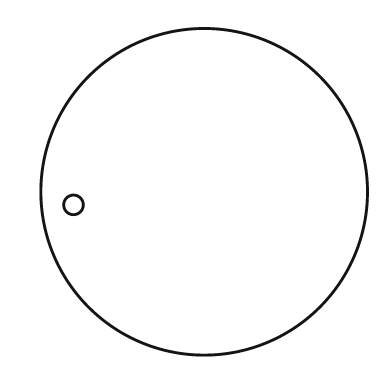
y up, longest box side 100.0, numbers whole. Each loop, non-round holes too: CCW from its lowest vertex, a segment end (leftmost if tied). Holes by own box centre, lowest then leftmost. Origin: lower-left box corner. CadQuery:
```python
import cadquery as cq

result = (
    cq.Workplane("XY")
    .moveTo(50.0, 50.0)
    .circle(50.0)
    .moveTo(10.0, 46.0)
    .circle(3.0)
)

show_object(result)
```